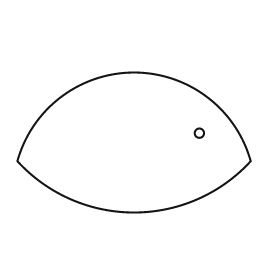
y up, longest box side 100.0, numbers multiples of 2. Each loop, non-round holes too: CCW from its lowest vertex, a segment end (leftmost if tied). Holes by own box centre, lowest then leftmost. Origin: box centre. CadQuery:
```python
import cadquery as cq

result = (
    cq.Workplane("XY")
    .moveTo(-50.0, -8.0)
    .threePointArc((0.0, -30.0), (50.0, -8.0))
    .threePointArc((0.0, 30.0), (-50.0, -8.0))
    .close()
    .moveTo(28.0, 4.0)
    .circle(2.0)
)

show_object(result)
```